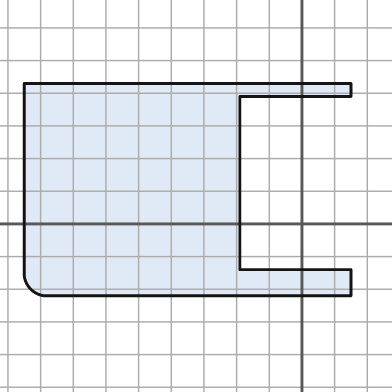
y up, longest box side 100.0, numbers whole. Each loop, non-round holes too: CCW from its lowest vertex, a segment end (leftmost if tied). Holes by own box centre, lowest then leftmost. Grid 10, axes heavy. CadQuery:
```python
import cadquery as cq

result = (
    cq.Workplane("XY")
    .moveTo(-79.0, -22.0)
    .lineTo(15.0, -22.0)
    .lineTo(15.0, -14.0)
    .lineTo(-19.0, -14.0)
    .lineTo(-19.0, 39.0)
    .lineTo(15.0, 39.0)
    .lineTo(15.0, 43.0)
    .lineTo(-85.0, 43.0)
    .lineTo(-85.0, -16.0)
    .threePointArc((-83.0, -20.0), (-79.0, -22.0))
    .close()
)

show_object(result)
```